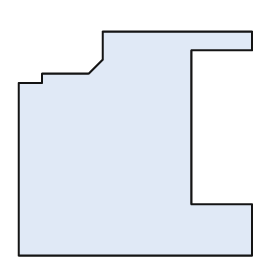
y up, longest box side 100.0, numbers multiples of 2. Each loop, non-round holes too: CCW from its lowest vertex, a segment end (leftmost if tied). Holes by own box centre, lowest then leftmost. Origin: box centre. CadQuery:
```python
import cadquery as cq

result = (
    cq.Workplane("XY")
    .moveTo(-50.0, -48.0)
    .lineTo(50.0, -48.0)
    .lineTo(50.0, -26.0)
    .lineTo(24.0, -26.0)
    .lineTo(24.0, 40.0)
    .lineTo(50.0, 40.0)
    .lineTo(50.0, 48.0)
    .lineTo(-14.0, 48.0)
    .lineTo(-14.0, 36.0)
    .lineTo(-20.0, 30.0)
    .lineTo(-40.0, 30.0)
    .lineTo(-40.0, 26.0)
    .lineTo(-50.0, 26.0)
    .close()
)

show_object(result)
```